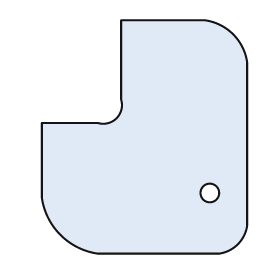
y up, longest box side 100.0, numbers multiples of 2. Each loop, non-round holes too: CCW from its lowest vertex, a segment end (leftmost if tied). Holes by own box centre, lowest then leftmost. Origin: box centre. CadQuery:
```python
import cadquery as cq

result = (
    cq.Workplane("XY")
    .moveTo(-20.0, -50.0)
    .lineTo(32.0, -50.0)
    .threePointArc((40.0, -46.0), (44.0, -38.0))
    .lineTo(44.0, 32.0)
    .threePointArc((38.0, 44.0), (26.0, 50.0))
    .lineTo(-10.0, 50.0)
    .lineTo(-10.0, 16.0)
    .threePointArc((-12.0, 8.0), (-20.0, 6.0))
    .lineTo(-44.0, 6.0)
    .lineTo(-44.0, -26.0)
    .threePointArc((-36.0, -42.0), (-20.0, -50.0))
    .close()
    .moveTo(28.0, -24.0)
    .circle(4.0)
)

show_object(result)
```